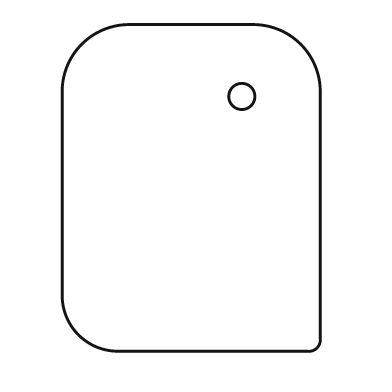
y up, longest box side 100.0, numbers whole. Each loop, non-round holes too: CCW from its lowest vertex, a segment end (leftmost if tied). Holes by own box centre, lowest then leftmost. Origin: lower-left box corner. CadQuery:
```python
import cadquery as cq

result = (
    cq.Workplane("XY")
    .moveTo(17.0, 0.0)
    .lineTo(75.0, 0.0)
    .threePointArc((78.0, 1.0), (79.0, 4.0))
    .lineTo(79.0, 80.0)
    .threePointArc((73.0, 94.0), (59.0, 100.0))
    .lineTo(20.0, 100.0)
    .threePointArc((6.0, 94.0), (0.0, 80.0))
    .lineTo(0.0, 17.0)
    .threePointArc((5.0, 5.0), (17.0, 0.0))
    .close()
    .moveTo(55.0, 78.0)
    .circle(4.0)
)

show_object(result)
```